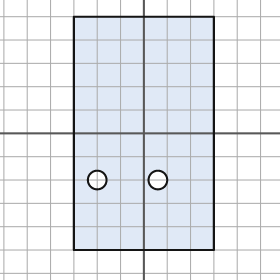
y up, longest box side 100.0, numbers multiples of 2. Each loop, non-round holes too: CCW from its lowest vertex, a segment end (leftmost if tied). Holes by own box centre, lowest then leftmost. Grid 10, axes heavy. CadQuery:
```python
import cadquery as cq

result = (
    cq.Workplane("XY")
    .moveTo(-30.0, -50.0)
    .lineTo(30.0, -50.0)
    .lineTo(30.0, 50.0)
    .lineTo(-30.0, 50.0)
    .close()
    .moveTo(-20.0, -20.0)
    .circle(4.0)
    .moveTo(6.0, -20.0)
    .circle(4.0)
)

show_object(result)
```